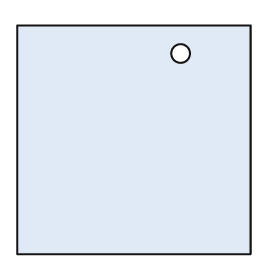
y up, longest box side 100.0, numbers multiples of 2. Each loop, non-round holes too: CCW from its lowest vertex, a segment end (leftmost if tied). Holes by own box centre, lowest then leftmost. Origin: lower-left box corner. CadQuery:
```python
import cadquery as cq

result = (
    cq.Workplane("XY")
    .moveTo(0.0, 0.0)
    .lineTo(100.0, 0.0)
    .lineTo(100.0, 98.0)
    .lineTo(0.0, 98.0)
    .close()
    .moveTo(70.0, 86.0)
    .circle(4.0)
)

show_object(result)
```